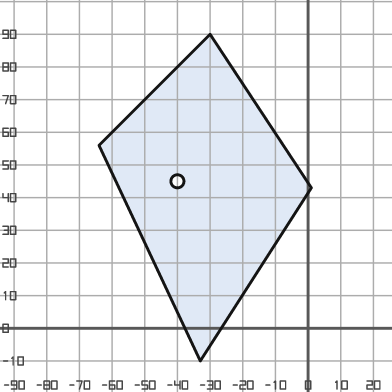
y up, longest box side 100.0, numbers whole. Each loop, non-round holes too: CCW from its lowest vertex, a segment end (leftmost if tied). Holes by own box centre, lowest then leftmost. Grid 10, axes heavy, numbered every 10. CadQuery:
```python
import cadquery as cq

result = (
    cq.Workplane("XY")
    .moveTo(-33.0, -10.0)
    .lineTo(1.0, 43.0)
    .lineTo(-30.0, 90.0)
    .lineTo(-64.0, 56.0)
    .close()
    .moveTo(-40.0, 45.0)
    .circle(2.0)
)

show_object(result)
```